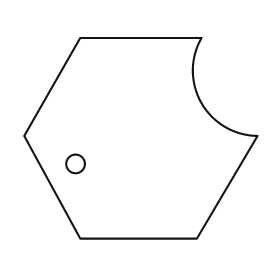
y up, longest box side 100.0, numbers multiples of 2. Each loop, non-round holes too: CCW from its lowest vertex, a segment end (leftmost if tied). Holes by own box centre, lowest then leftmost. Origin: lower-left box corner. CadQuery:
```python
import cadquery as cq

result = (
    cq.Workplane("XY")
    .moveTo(24.0, 0.0)
    .lineTo(74.0, 0.0)
    .lineTo(100.0, 44.0)
    .threePointArc((76.0, 58.0), (76.0, 86.0))
    .lineTo(24.0, 86.0)
    .lineTo(0.0, 44.0)
    .close()
    .moveTo(22.0, 32.0)
    .circle(4.0)
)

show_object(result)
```